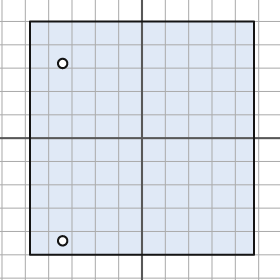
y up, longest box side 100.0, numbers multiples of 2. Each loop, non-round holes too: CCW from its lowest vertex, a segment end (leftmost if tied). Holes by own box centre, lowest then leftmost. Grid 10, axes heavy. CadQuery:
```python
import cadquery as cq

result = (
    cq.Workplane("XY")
    .moveTo(-48.0, -50.0)
    .lineTo(48.0, -50.0)
    .lineTo(48.0, 50.0)
    .lineTo(-48.0, 50.0)
    .close()
    .moveTo(-34.0, -44.0)
    .circle(2.0)
    .moveTo(-34.0, 32.0)
    .circle(2.0)
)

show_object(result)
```